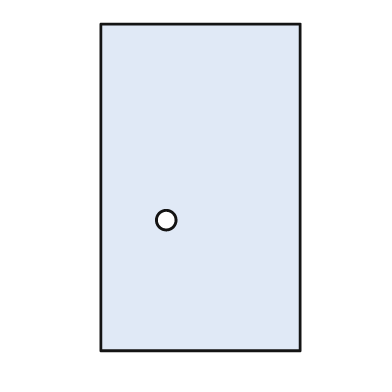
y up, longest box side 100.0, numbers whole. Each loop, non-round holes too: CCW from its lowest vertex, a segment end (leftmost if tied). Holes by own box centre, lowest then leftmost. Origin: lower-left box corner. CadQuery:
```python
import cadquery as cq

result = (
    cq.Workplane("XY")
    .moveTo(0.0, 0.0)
    .lineTo(61.0, 0.0)
    .lineTo(61.0, 100.0)
    .lineTo(0.0, 100.0)
    .close()
    .moveTo(20.0, 40.0)
    .circle(3.0)
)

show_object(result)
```